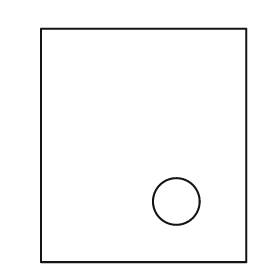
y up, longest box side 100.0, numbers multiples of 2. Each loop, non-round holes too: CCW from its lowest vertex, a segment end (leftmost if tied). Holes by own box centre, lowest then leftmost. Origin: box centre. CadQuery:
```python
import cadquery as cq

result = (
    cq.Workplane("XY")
    .moveTo(-44.0, -50.0)
    .lineTo(44.0, -50.0)
    .lineTo(44.0, 50.0)
    .lineTo(-44.0, 50.0)
    .close()
    .moveTo(14.0, -24.0)
    .circle(10.0)
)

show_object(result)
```